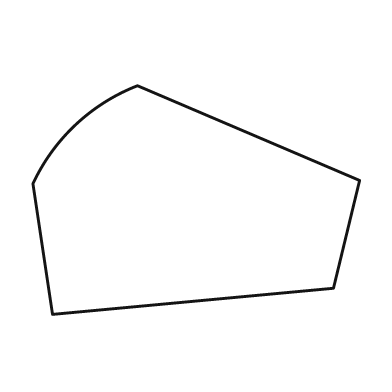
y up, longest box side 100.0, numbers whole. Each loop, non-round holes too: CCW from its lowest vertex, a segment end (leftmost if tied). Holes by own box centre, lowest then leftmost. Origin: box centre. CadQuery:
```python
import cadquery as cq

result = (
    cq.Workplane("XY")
    .moveTo(-44.0, -35.0)
    .lineTo(42.0, -27.0)
    .lineTo(50.0, 6.0)
    .lineTo(-18.0, 35.0)
    .threePointArc((-37.0, 23.0), (-50.0, 5.0))
    .close()
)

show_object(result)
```